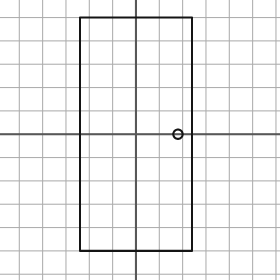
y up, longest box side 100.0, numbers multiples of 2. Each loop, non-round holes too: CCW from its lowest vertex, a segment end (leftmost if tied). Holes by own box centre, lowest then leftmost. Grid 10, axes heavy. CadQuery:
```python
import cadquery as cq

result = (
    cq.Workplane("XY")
    .moveTo(-24.0, -50.0)
    .lineTo(24.0, -50.0)
    .lineTo(24.0, 50.0)
    .lineTo(-24.0, 50.0)
    .close()
    .moveTo(18.0, 0.0)
    .circle(2.0)
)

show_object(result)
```